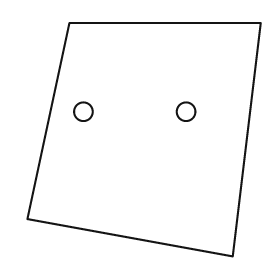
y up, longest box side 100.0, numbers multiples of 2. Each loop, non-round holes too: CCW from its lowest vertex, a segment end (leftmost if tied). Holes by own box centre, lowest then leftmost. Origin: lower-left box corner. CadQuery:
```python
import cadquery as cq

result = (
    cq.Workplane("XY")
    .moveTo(88.0, 0.0)
    .lineTo(100.0, 100.0)
    .lineTo(18.0, 100.0)
    .lineTo(0.0, 16.0)
    .close()
    .moveTo(24.0, 62.0)
    .circle(4.0)
    .moveTo(68.0, 62.0)
    .circle(4.0)
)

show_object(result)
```